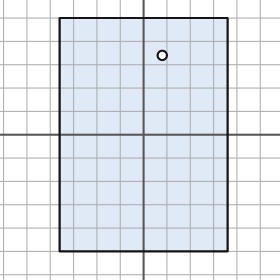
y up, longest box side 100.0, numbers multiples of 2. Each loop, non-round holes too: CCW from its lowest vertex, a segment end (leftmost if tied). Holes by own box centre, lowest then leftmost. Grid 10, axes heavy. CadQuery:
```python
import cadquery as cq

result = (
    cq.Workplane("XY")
    .moveTo(-36.0, -50.0)
    .lineTo(36.0, -50.0)
    .lineTo(36.0, 50.0)
    .lineTo(-36.0, 50.0)
    .close()
    .moveTo(8.0, 34.0)
    .circle(2.0)
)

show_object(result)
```